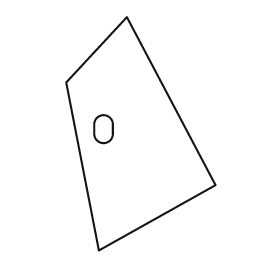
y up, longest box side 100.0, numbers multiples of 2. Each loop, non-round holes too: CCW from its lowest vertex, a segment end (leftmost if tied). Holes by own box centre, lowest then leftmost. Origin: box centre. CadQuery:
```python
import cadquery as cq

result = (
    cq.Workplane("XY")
    .moveTo(-18.0, -50.0)
    .lineTo(32.0, -22.0)
    .lineTo(-6.0, 50.0)
    .lineTo(-32.0, 22.0)
    .close()
    .moveTo(-20.0, 0.0)
    .threePointArc((-16.0, -4.0), (-12.0, 0.0))
    .lineTo(-12.0, 4.0)
    .threePointArc((-16.0, 8.0), (-20.0, 4.0))
    .close()
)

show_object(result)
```